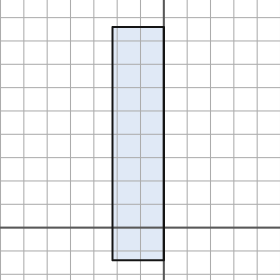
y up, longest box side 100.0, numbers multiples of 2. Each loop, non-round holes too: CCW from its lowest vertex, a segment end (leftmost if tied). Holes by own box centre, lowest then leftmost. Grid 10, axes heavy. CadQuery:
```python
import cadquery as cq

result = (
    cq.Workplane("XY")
    .moveTo(-22.0, -14.0)
    .lineTo(0.0, -14.0)
    .lineTo(0.0, 86.0)
    .lineTo(-22.0, 86.0)
    .close()
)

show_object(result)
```